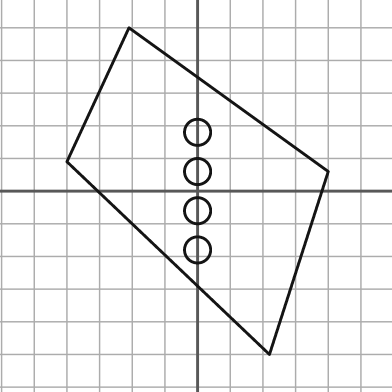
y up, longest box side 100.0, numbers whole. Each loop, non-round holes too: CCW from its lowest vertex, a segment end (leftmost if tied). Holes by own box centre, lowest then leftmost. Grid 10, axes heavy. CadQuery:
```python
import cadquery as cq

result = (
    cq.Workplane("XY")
    .moveTo(22.0, -50.0)
    .lineTo(40.0, 6.0)
    .lineTo(-21.0, 50.0)
    .lineTo(-40.0, 9.0)
    .close()
    .moveTo(0.0, -18.0)
    .circle(4.0)
    .moveTo(0.0, -6.0)
    .circle(4.0)
    .moveTo(0.0, 6.0)
    .circle(4.0)
    .moveTo(0.0, 18.0)
    .circle(4.0)
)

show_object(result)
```